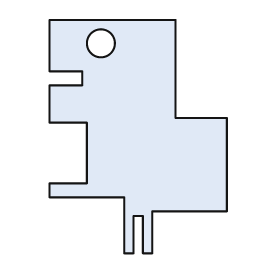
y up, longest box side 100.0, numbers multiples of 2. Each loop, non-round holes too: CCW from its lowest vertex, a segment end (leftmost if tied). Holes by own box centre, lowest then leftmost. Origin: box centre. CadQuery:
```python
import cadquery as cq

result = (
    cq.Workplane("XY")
    .moveTo(-6.0, -50.0)
    .lineTo(-2.0, -50.0)
    .lineTo(-2.0, -34.0)
    .lineTo(2.0, -34.0)
    .lineTo(2.0, -50.0)
    .lineTo(6.0, -50.0)
    .lineTo(6.0, -32.0)
    .lineTo(38.0, -32.0)
    .lineTo(38.0, 8.0)
    .lineTo(16.0, 8.0)
    .lineTo(16.0, 50.0)
    .lineTo(-38.0, 50.0)
    .lineTo(-38.0, 28.0)
    .lineTo(-24.0, 28.0)
    .lineTo(-24.0, 22.0)
    .lineTo(-38.0, 22.0)
    .lineTo(-38.0, 6.0)
    .lineTo(-22.0, 6.0)
    .lineTo(-22.0, -20.0)
    .lineTo(-38.0, -20.0)
    .lineTo(-38.0, -26.0)
    .lineTo(-6.0, -26.0)
    .close()
    .moveTo(-16.0, 40.0)
    .circle(6.0)
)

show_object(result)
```